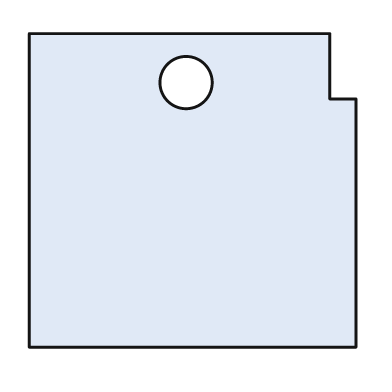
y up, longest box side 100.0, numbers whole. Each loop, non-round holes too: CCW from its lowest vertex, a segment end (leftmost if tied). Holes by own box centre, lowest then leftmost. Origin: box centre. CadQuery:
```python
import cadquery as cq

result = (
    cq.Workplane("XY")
    .moveTo(-50.0, -48.0)
    .lineTo(50.0, -48.0)
    .lineTo(50.0, 28.0)
    .lineTo(42.0, 28.0)
    .lineTo(42.0, 48.0)
    .lineTo(-50.0, 48.0)
    .close()
    .moveTo(-2.0, 33.0)
    .circle(8.0)
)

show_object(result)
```